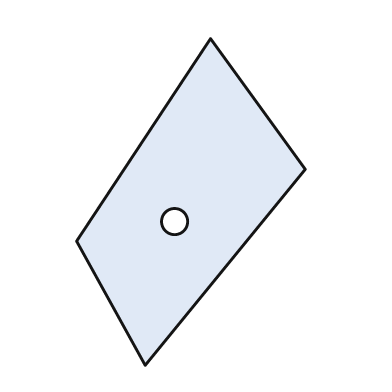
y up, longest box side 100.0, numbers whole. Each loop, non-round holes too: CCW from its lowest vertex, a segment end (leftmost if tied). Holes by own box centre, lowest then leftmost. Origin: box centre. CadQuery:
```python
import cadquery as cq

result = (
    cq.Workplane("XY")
    .moveTo(-14.0, -50.0)
    .lineTo(35.0, 10.0)
    .lineTo(6.0, 50.0)
    .lineTo(-35.0, -12.0)
    .close()
    .moveTo(-5.0, -6.0)
    .circle(4.0)
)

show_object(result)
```